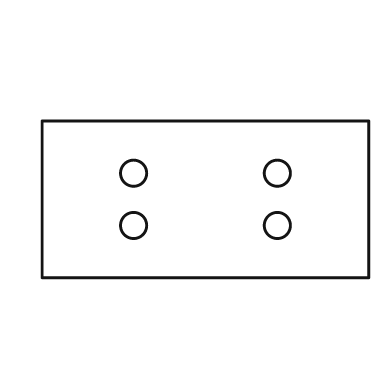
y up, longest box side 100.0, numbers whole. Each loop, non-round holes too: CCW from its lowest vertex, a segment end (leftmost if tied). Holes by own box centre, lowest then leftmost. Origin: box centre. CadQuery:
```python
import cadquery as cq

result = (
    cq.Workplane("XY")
    .moveTo(-50.0, -24.0)
    .lineTo(50.0, -24.0)
    .lineTo(50.0, 24.0)
    .lineTo(-50.0, 24.0)
    .close()
    .moveTo(-22.0, -8.0)
    .circle(4.0)
    .moveTo(22.0, -8.0)
    .circle(4.0)
    .moveTo(-22.0, 8.0)
    .circle(4.0)
    .moveTo(22.0, 8.0)
    .circle(4.0)
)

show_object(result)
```